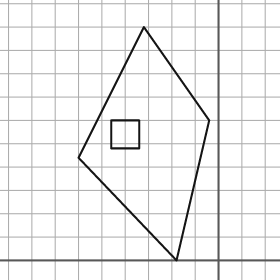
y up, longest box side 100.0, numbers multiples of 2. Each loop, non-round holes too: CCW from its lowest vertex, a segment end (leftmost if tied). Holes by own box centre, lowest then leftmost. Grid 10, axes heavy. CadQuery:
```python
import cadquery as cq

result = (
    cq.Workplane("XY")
    .moveTo(-18.0, 0.0)
    .lineTo(-4.0, 60.0)
    .lineTo(-32.0, 100.0)
    .lineTo(-60.0, 44.0)
    .close()
    .moveTo(-46.0, 48.0)
    .lineTo(-34.0, 48.0)
    .lineTo(-34.0, 60.0)
    .lineTo(-46.0, 60.0)
    .close()
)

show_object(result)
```